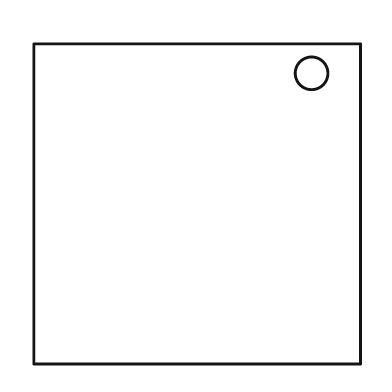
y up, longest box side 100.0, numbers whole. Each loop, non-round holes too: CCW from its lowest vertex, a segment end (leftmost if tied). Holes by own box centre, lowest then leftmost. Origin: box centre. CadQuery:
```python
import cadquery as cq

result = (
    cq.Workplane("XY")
    .moveTo(-50.0, -49.0)
    .lineTo(50.0, -49.0)
    .lineTo(50.0, 49.0)
    .lineTo(-50.0, 49.0)
    .close()
    .moveTo(35.0, 40.0)
    .circle(5.0)
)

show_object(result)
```